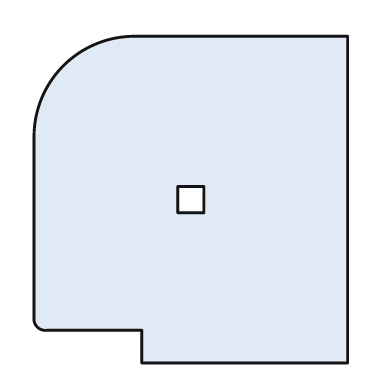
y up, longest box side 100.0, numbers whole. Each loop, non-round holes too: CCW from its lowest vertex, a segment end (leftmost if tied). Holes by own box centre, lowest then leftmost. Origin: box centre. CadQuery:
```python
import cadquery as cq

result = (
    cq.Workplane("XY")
    .moveTo(-15.0, -50.0)
    .lineTo(48.0, -50.0)
    .lineTo(48.0, 50.0)
    .lineTo(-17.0, 50.0)
    .threePointArc((-39.0, 41.0), (-48.0, 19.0))
    .lineTo(-48.0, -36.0)
    .threePointArc((-47.0, -39.0), (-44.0, -40.0))
    .lineTo(-15.0, -40.0)
    .close()
    .moveTo(-4.0, -4.0)
    .lineTo(4.0, -4.0)
    .lineTo(4.0, 4.0)
    .lineTo(-4.0, 4.0)
    .close()
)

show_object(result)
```